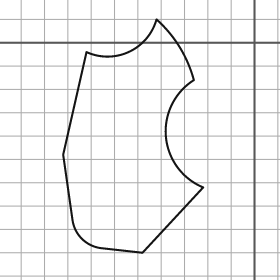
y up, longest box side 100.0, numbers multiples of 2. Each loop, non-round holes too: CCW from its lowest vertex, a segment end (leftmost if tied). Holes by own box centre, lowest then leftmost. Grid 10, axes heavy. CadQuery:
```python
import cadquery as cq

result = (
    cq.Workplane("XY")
    .moveTo(-48.0, -90.0)
    .lineTo(-22.0, -62.0)
    .threePointArc((-38.0, -40.0), (-26.0, -16.0))
    .threePointArc((-32.0, -2.0), (-42.0, 10.0))
    .threePointArc((-54.0, -4.0), (-72.0, -4.0))
    .lineTo(-82.0, -48.0)
    .lineTo(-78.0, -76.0)
    .threePointArc((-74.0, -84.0), (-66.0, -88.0))
    .close()
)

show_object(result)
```